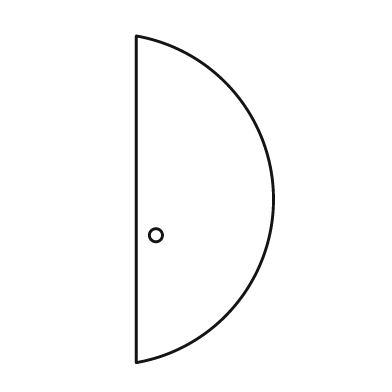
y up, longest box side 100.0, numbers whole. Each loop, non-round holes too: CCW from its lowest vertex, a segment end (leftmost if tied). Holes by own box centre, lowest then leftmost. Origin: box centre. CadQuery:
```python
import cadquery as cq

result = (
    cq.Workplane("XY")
    .moveTo(-21.0, -50.0)
    .threePointArc((21.0, 0.0), (-21.0, 50.0))
    .close()
    .moveTo(-15.0, -11.0)
    .circle(2.0)
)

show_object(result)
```